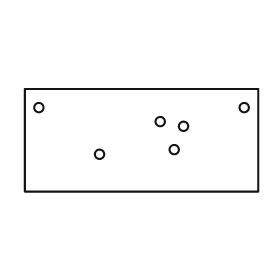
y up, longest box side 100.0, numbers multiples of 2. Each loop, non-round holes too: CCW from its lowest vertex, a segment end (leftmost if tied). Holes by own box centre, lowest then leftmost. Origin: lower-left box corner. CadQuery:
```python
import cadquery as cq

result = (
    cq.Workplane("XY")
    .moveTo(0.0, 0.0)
    .lineTo(100.0, 0.0)
    .lineTo(100.0, 44.0)
    .lineTo(0.0, 44.0)
    .close()
    .moveTo(32.0, 16.0)
    .circle(2.0)
    .moveTo(64.0, 18.0)
    .circle(2.0)
    .moveTo(68.0, 28.0)
    .circle(2.0)
    .moveTo(58.0, 30.0)
    .circle(2.0)
    .moveTo(6.0, 36.0)
    .circle(2.0)
    .moveTo(94.0, 36.0)
    .circle(2.0)
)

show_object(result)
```